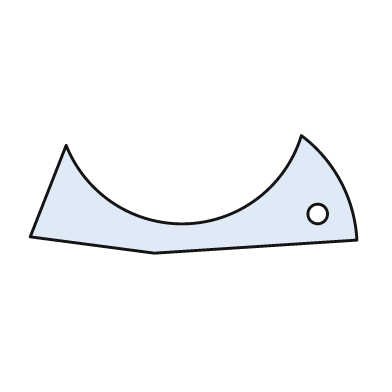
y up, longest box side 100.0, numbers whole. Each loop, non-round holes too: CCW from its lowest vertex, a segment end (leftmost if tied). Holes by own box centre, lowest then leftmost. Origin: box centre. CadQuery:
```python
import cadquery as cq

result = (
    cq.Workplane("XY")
    .moveTo(-12.0, -18.0)
    .lineTo(50.0, -14.0)
    .threePointArc((45.0, 4.0), (33.0, 18.0))
    .threePointArc((-2.0, -9.0), (-39.0, 15.0))
    .lineTo(-50.0, -13.0)
    .close()
    .moveTo(38.0, -6.0)
    .circle(3.0)
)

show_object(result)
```